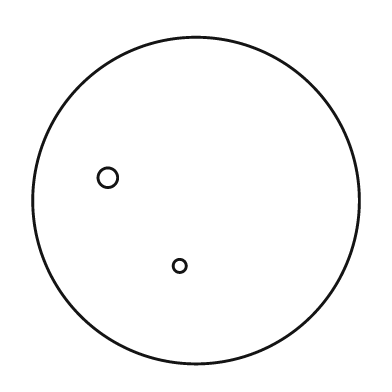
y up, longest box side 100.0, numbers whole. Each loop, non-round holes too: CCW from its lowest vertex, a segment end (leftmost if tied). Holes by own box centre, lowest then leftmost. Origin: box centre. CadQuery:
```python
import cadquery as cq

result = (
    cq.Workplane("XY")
    .moveTo(0.0, 0.0)
    .circle(50.0)
    .moveTo(-5.0, -20.0)
    .circle(2.0)
    .moveTo(-27.0, 7.0)
    .circle(3.0)
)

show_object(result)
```